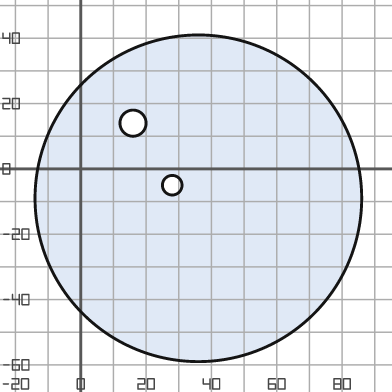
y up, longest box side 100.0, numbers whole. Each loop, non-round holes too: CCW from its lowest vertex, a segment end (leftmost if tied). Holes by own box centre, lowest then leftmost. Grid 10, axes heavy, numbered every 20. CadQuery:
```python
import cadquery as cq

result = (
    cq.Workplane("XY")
    .moveTo(36.0, -9.0)
    .circle(50.0)
    .moveTo(28.0, -5.0)
    .circle(3.0)
    .moveTo(16.0, 14.0)
    .circle(4.0)
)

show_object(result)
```